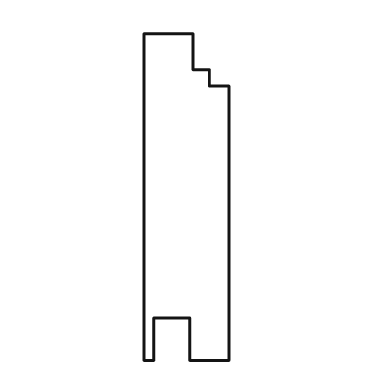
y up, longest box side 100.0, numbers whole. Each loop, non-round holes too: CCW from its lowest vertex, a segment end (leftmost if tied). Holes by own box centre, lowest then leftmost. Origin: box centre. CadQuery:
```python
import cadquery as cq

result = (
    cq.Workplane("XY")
    .moveTo(-13.0, -50.0)
    .lineTo(-10.0, -50.0)
    .lineTo(-10.0, -37.0)
    .lineTo(1.0, -37.0)
    .lineTo(1.0, -50.0)
    .lineTo(13.0, -50.0)
    .lineTo(13.0, 34.0)
    .lineTo(7.0, 34.0)
    .lineTo(7.0, 39.0)
    .lineTo(2.0, 39.0)
    .lineTo(2.0, 50.0)
    .lineTo(-13.0, 50.0)
    .close()
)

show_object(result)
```